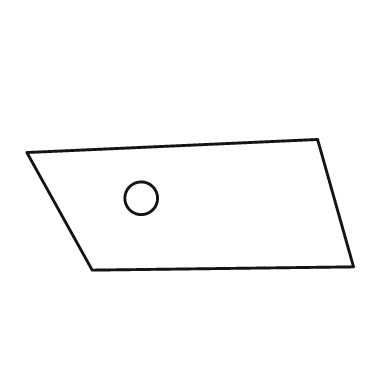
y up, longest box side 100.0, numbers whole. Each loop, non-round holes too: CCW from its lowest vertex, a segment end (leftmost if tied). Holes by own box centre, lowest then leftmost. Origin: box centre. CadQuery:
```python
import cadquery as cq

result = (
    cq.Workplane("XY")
    .moveTo(-30.0, -20.0)
    .lineTo(50.0, -19.0)
    .lineTo(39.0, 20.0)
    .lineTo(-50.0, 16.0)
    .close()
    .moveTo(-15.0, 2.0)
    .circle(5.0)
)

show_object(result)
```